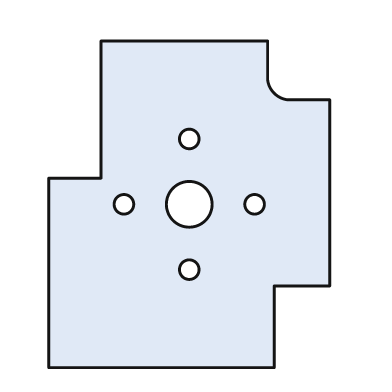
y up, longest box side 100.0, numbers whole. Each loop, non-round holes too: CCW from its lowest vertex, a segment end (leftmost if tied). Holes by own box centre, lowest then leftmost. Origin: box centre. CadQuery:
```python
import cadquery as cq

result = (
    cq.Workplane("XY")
    .moveTo(-43.0, -50.0)
    .lineTo(26.0, -50.0)
    .lineTo(26.0, -25.0)
    .lineTo(43.0, -25.0)
    .lineTo(43.0, 32.0)
    .lineTo(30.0, 32.0)
    .threePointArc((26.0, 34.0), (24.0, 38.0))
    .lineTo(24.0, 50.0)
    .lineTo(-27.0, 50.0)
    .lineTo(-27.0, 8.0)
    .lineTo(-43.0, 8.0)
    .close()
    .moveTo(0.0, -20.0)
    .circle(3.0)
    .moveTo(-20.0, 0.0)
    .circle(3.0)
    .moveTo(0.0, 0.0)
    .circle(7.0)
    .moveTo(20.0, 0.0)
    .circle(3.0)
    .moveTo(0.0, 20.0)
    .circle(3.0)
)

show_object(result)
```